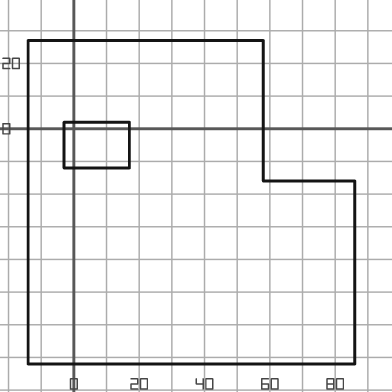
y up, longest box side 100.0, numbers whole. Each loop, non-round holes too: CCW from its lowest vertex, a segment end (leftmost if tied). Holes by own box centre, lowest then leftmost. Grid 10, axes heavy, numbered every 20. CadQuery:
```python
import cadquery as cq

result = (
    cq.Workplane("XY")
    .moveTo(-14.0, -72.0)
    .lineTo(86.0, -72.0)
    .lineTo(86.0, -16.0)
    .lineTo(58.0, -16.0)
    .lineTo(58.0, 27.0)
    .lineTo(-14.0, 27.0)
    .close()
    .moveTo(-3.0, -12.0)
    .lineTo(17.0, -12.0)
    .lineTo(17.0, 2.0)
    .lineTo(-3.0, 2.0)
    .close()
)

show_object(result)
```